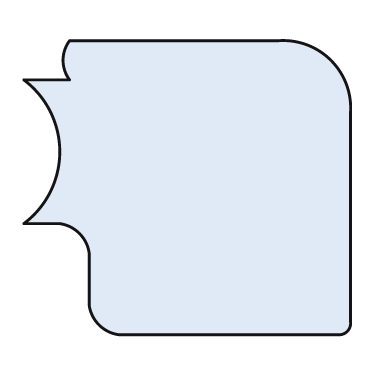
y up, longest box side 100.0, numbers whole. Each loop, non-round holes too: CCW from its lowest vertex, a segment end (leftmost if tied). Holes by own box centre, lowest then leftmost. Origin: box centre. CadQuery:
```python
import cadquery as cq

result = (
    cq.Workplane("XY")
    .moveTo(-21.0, -45.0)
    .lineTo(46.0, -45.0)
    .threePointArc((49.0, -44.0), (50.0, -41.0))
    .lineTo(50.0, 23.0)
    .threePointArc((44.0, 39.0), (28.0, 45.0))
    .lineTo(-36.0, 45.0)
    .threePointArc((-38.0, 39.0), (-36.0, 33.0))
    .lineTo(-50.0, 33.0)
    .threePointArc((-39.0, 11.0), (-50.0, -11.0))
    .lineTo(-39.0, -11.0)
    .threePointArc((-33.0, -14.0), (-30.0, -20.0))
    .lineTo(-30.0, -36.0)
    .threePointArc((-27.0, -42.0), (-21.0, -45.0))
    .close()
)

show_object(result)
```